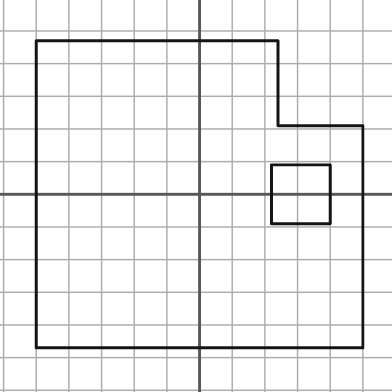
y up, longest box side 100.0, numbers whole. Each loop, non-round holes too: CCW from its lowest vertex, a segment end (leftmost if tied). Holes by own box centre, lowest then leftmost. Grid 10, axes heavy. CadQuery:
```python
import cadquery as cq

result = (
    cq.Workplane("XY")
    .moveTo(-50.0, -47.0)
    .lineTo(50.0, -47.0)
    .lineTo(50.0, 21.0)
    .lineTo(24.0, 21.0)
    .lineTo(24.0, 47.0)
    .lineTo(-50.0, 47.0)
    .close()
    .moveTo(22.0, -9.0)
    .lineTo(40.0, -9.0)
    .lineTo(40.0, 9.0)
    .lineTo(22.0, 9.0)
    .close()
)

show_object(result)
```